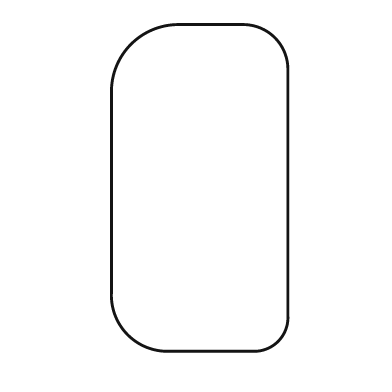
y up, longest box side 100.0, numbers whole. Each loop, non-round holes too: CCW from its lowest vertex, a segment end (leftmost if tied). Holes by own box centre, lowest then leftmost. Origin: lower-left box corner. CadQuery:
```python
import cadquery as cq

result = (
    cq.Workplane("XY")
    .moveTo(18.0, 0.0)
    .lineTo(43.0, 0.0)
    .threePointArc((51.0, 3.0), (54.0, 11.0))
    .lineTo(54.0, 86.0)
    .threePointArc((50.0, 96.0), (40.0, 100.0))
    .lineTo(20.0, 100.0)
    .threePointArc((6.0, 94.0), (0.0, 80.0))
    .lineTo(0.0, 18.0)
    .threePointArc((5.0, 5.0), (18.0, 0.0))
    .close()
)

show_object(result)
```